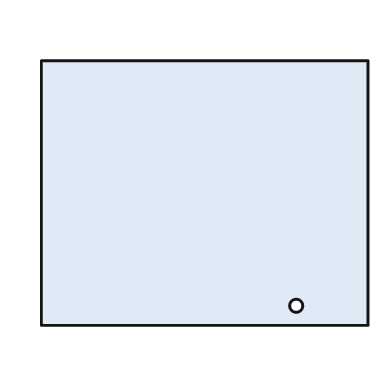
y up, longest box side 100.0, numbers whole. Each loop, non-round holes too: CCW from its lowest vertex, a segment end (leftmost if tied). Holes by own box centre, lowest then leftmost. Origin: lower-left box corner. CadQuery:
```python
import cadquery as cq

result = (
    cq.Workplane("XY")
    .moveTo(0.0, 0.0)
    .lineTo(100.0, 0.0)
    .lineTo(100.0, 81.0)
    .lineTo(0.0, 81.0)
    .close()
    .moveTo(78.0, 6.0)
    .circle(2.0)
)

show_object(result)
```